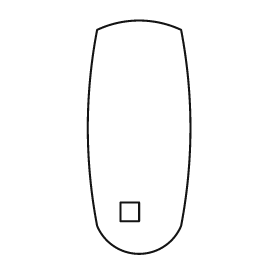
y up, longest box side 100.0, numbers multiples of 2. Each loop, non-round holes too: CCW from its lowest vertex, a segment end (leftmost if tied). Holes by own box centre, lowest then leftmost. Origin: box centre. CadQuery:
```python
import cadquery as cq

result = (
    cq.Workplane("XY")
    .moveTo(-18.0, -38.0)
    .threePointArc((0.0, -50.0), (18.0, -38.0))
    .threePointArc((22.0, 4.0), (18.0, 46.0))
    .threePointArc((0.0, 50.0), (-18.0, 46.0))
    .threePointArc((-22.0, 4.0), (-18.0, -38.0))
    .close()
    .moveTo(-8.0, -36.0)
    .lineTo(0.0, -36.0)
    .lineTo(0.0, -28.0)
    .lineTo(-8.0, -28.0)
    .close()
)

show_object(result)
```